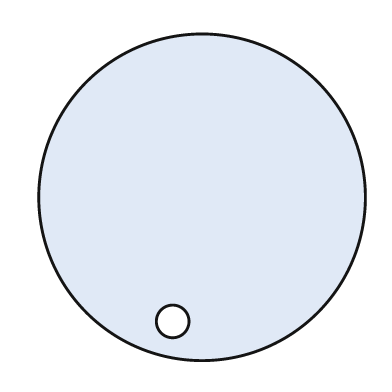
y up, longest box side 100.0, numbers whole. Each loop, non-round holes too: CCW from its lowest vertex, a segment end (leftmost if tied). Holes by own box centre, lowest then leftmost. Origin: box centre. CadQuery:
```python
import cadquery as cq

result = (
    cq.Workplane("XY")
    .moveTo(0.0, 0.0)
    .circle(50.0)
    .moveTo(-9.0, -38.0)
    .circle(5.0)
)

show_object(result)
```